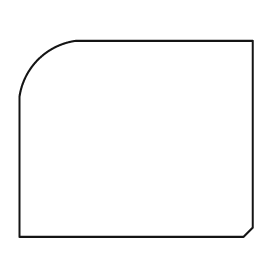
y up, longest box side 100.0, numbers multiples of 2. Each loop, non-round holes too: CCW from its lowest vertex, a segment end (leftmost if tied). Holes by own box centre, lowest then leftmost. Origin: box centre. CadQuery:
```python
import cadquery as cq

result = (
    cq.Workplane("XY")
    .moveTo(-50.0, -42.0)
    .lineTo(46.0, -42.0)
    .lineTo(50.0, -38.0)
    .lineTo(50.0, 42.0)
    .lineTo(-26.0, 42.0)
    .threePointArc((-42.0, 34.0), (-50.0, 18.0))
    .close()
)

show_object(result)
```